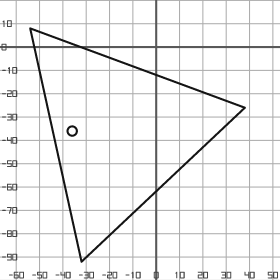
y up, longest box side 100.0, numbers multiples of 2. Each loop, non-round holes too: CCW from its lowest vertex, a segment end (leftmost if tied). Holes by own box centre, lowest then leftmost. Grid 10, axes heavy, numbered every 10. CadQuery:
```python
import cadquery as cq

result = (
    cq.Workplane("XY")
    .moveTo(-32.0, -92.0)
    .lineTo(38.0, -26.0)
    .lineTo(-54.0, 8.0)
    .close()
    .moveTo(-36.0, -36.0)
    .circle(2.0)
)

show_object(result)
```